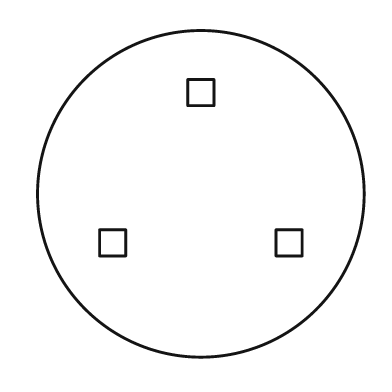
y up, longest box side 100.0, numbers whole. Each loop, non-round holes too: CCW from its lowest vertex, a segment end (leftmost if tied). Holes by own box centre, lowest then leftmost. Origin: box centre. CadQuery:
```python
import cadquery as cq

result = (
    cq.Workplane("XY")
    .moveTo(0.0, 0.0)
    .circle(50.0)
    .moveTo(-31.0, -19.0)
    .lineTo(-23.0, -19.0)
    .lineTo(-23.0, -11.0)
    .lineTo(-31.0, -11.0)
    .close()
    .moveTo(23.0, -19.0)
    .lineTo(31.0, -19.0)
    .lineTo(31.0, -11.0)
    .lineTo(23.0, -11.0)
    .close()
    .moveTo(-4.0, 27.0)
    .lineTo(4.0, 27.0)
    .lineTo(4.0, 35.0)
    .lineTo(-4.0, 35.0)
    .close()
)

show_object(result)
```